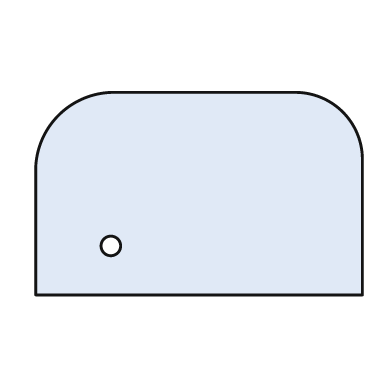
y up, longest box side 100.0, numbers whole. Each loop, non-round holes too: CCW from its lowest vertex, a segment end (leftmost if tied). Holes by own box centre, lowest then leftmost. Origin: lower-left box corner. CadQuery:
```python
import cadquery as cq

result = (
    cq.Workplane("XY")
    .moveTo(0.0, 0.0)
    .lineTo(100.0, 0.0)
    .lineTo(100.0, 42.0)
    .threePointArc((94.0, 56.0), (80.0, 62.0))
    .lineTo(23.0, 62.0)
    .threePointArc((7.0, 55.0), (0.0, 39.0))
    .close()
    .moveTo(23.0, 15.0)
    .circle(3.0)
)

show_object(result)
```